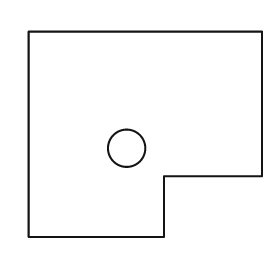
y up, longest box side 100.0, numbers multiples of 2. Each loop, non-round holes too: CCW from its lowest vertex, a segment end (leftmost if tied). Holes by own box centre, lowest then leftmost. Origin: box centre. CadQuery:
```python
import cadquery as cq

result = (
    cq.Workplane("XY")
    .moveTo(-50.0, -44.0)
    .lineTo(8.0, -44.0)
    .lineTo(8.0, -18.0)
    .lineTo(50.0, -18.0)
    .lineTo(50.0, 44.0)
    .lineTo(-50.0, 44.0)
    .close()
    .moveTo(-8.0, -6.0)
    .circle(8.0)
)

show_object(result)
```